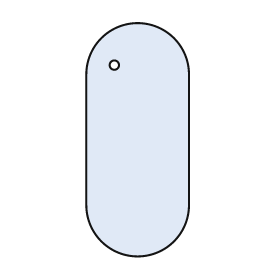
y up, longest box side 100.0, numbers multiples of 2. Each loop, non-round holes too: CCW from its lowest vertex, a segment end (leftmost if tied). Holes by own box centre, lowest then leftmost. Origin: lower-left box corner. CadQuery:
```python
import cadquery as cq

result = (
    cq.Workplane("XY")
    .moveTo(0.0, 22.0)
    .threePointArc((22.0, 0.0), (44.0, 22.0))
    .lineTo(44.0, 78.0)
    .threePointArc((22.0, 100.0), (0.0, 78.0))
    .close()
    .moveTo(12.0, 82.0)
    .circle(2.0)
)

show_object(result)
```